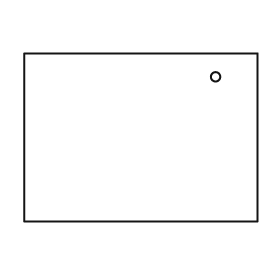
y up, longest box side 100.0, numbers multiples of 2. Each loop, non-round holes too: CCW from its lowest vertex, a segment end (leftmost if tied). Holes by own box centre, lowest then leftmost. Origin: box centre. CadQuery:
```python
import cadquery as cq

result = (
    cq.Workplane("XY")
    .moveTo(-50.0, -36.0)
    .lineTo(50.0, -36.0)
    .lineTo(50.0, 36.0)
    .lineTo(-50.0, 36.0)
    .close()
    .moveTo(32.0, 26.0)
    .circle(2.0)
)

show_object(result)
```